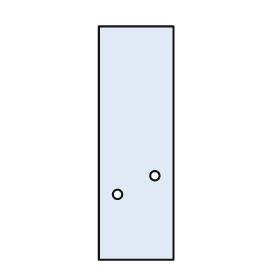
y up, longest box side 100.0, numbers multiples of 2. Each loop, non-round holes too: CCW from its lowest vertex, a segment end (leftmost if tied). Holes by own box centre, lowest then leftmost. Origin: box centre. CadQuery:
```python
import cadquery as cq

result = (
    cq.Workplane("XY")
    .moveTo(-16.0, -50.0)
    .lineTo(16.0, -50.0)
    .lineTo(16.0, 50.0)
    .lineTo(-16.0, 50.0)
    .close()
    .moveTo(-8.0, -22.0)
    .circle(2.0)
    .moveTo(8.0, -14.0)
    .circle(2.0)
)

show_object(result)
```